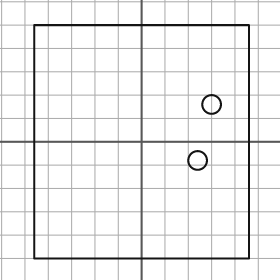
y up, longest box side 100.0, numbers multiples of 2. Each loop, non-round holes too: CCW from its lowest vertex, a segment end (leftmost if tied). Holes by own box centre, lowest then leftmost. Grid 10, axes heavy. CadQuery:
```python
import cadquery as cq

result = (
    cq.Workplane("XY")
    .moveTo(-46.0, -50.0)
    .lineTo(46.0, -50.0)
    .lineTo(46.0, 50.0)
    .lineTo(-46.0, 50.0)
    .close()
    .moveTo(24.0, -8.0)
    .circle(4.0)
    .moveTo(30.0, 16.0)
    .circle(4.0)
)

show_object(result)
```